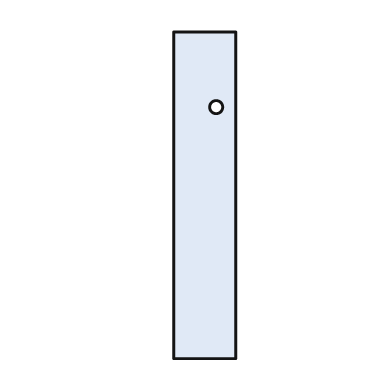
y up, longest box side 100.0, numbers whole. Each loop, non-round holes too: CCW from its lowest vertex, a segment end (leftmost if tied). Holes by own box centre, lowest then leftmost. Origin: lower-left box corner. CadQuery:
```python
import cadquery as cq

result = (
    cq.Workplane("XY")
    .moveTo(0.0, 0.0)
    .lineTo(19.0, 0.0)
    .lineTo(19.0, 100.0)
    .lineTo(0.0, 100.0)
    .close()
    .moveTo(13.0, 77.0)
    .circle(2.0)
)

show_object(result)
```